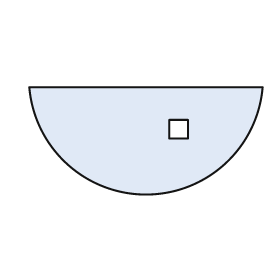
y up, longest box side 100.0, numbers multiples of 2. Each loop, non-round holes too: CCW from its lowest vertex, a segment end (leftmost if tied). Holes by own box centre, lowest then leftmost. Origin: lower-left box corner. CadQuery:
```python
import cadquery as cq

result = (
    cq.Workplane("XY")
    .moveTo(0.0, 46.0)
    .threePointArc((50.0, 0.0), (100.0, 46.0))
    .close()
    .moveTo(60.0, 24.0)
    .lineTo(68.0, 24.0)
    .lineTo(68.0, 32.0)
    .lineTo(60.0, 32.0)
    .close()
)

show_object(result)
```